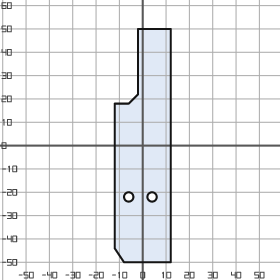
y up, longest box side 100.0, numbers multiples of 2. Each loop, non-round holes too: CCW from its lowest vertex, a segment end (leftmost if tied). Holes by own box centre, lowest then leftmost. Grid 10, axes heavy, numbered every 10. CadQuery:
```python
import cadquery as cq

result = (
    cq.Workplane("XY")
    .moveTo(-8.0, -50.0)
    .lineTo(12.0, -50.0)
    .lineTo(12.0, 50.0)
    .lineTo(-2.0, 50.0)
    .lineTo(-2.0, 22.0)
    .lineTo(-6.0, 18.0)
    .lineTo(-12.0, 18.0)
    .lineTo(-12.0, -44.0)
    .close()
    .moveTo(-6.0, -22.0)
    .circle(2.0)
    .moveTo(4.0, -22.0)
    .circle(2.0)
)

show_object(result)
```